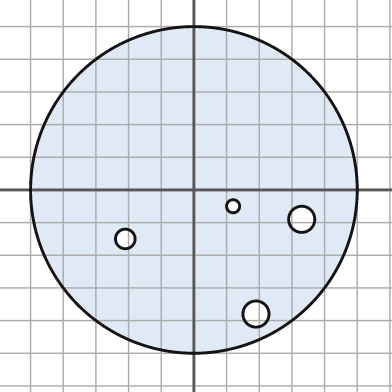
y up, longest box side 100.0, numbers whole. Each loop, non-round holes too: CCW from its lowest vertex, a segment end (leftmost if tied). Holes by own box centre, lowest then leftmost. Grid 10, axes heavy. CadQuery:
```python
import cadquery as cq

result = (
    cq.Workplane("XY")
    .moveTo(0.0, 0.0)
    .circle(50.0)
    .moveTo(19.0, -38.0)
    .circle(4.0)
    .moveTo(-21.0, -15.0)
    .circle(3.0)
    .moveTo(33.0, -9.0)
    .circle(4.0)
    .moveTo(12.0, -5.0)
    .circle(2.0)
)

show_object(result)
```